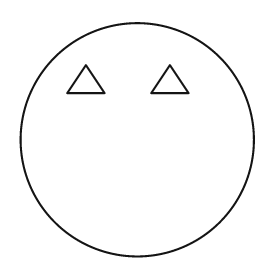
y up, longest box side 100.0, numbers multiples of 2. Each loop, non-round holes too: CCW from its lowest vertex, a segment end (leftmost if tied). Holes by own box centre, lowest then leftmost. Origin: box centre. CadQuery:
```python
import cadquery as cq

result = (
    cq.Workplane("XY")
    .moveTo(0.0, 0.0)
    .circle(50.0)
    .moveTo(-30.0, 20.0)
    .lineTo(-14.0, 20.0)
    .lineTo(-22.0, 32.0)
    .close()
    .moveTo(6.0, 20.0)
    .lineTo(22.0, 20.0)
    .lineTo(14.0, 32.0)
    .close()
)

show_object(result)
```